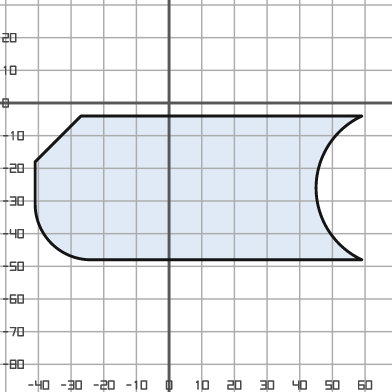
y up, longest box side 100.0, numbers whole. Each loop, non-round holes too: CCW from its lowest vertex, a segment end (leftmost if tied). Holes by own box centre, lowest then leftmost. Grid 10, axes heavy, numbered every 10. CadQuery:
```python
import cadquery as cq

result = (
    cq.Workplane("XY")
    .moveTo(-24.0, -48.0)
    .lineTo(59.0, -48.0)
    .threePointArc((45.0, -26.0), (59.0, -4.0))
    .lineTo(-27.0, -4.0)
    .lineTo(-41.0, -18.0)
    .lineTo(-41.0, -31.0)
    .threePointArc((-36.0, -43.0), (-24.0, -48.0))
    .close()
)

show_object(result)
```